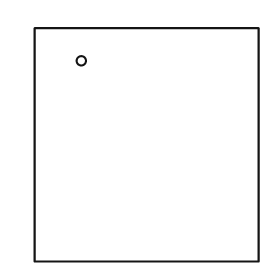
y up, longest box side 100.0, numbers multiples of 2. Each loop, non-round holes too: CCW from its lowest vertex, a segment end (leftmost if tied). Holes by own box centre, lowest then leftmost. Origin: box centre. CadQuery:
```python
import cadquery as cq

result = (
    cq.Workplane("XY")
    .moveTo(-48.0, -50.0)
    .lineTo(48.0, -50.0)
    .lineTo(48.0, 50.0)
    .lineTo(-48.0, 50.0)
    .close()
    .moveTo(-28.0, 36.0)
    .circle(2.0)
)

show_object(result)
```